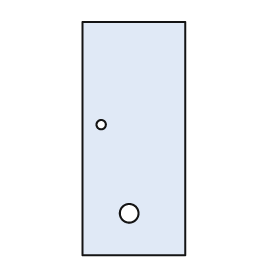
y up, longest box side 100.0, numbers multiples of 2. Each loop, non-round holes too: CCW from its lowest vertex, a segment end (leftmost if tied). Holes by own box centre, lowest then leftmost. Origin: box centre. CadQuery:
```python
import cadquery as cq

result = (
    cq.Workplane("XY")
    .moveTo(-22.0, -50.0)
    .lineTo(22.0, -50.0)
    .lineTo(22.0, 50.0)
    .lineTo(-22.0, 50.0)
    .close()
    .moveTo(-2.0, -32.0)
    .circle(4.0)
    .moveTo(-14.0, 6.0)
    .circle(2.0)
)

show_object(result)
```